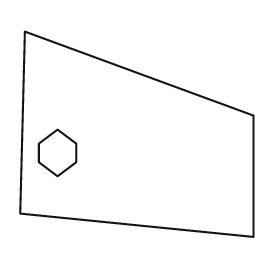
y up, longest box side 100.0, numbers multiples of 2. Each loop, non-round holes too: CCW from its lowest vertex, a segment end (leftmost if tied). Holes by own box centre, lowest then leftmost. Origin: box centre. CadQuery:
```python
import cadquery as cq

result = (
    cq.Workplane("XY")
    .moveTo(50.0, -44.0)
    .lineTo(50.0, 8.0)
    .lineTo(-48.0, 44.0)
    .lineTo(-50.0, -34.0)
    .close()
    .moveTo(-34.0, -18.0)
    .lineTo(-26.0, -12.0)
    .lineTo(-26.0, -4.0)
    .lineTo(-34.0, 2.0)
    .lineTo(-42.0, -4.0)
    .lineTo(-42.0, -12.0)
    .close()
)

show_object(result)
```